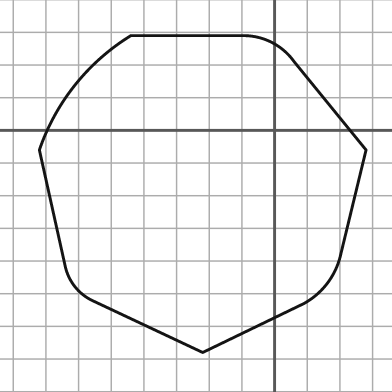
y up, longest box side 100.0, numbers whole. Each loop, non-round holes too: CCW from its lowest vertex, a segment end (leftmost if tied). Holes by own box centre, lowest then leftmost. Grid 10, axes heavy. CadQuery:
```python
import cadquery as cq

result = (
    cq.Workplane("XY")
    .moveTo(-22.0, -68.0)
    .lineTo(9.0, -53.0)
    .threePointArc((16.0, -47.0), (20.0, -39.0))
    .lineTo(28.0, -6.0)
    .lineTo(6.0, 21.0)
    .threePointArc((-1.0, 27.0), (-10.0, 29.0))
    .lineTo(-44.0, 29.0)
    .threePointArc((-61.0, 14.0), (-72.0, -6.0))
    .lineTo(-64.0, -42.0)
    .threePointArc((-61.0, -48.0), (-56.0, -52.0))
    .close()
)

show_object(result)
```